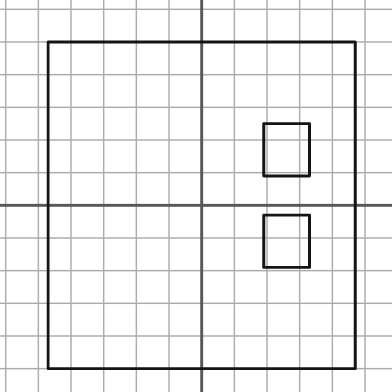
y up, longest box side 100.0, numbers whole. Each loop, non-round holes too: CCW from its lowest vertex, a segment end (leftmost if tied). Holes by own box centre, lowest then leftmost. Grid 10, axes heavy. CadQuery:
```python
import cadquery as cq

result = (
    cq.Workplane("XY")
    .moveTo(-47.0, -50.0)
    .lineTo(47.0, -50.0)
    .lineTo(47.0, 50.0)
    .lineTo(-47.0, 50.0)
    .close()
    .moveTo(19.0, -19.0)
    .lineTo(33.0, -19.0)
    .lineTo(33.0, -3.0)
    .lineTo(19.0, -3.0)
    .close()
    .moveTo(19.0, 9.0)
    .lineTo(33.0, 9.0)
    .lineTo(33.0, 25.0)
    .lineTo(19.0, 25.0)
    .close()
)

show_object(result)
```